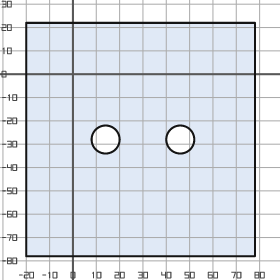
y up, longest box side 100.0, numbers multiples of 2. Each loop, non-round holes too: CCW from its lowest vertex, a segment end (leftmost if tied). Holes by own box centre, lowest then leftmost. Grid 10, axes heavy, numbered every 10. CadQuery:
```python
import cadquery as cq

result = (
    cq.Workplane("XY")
    .moveTo(-20.0, -78.0)
    .lineTo(78.0, -78.0)
    .lineTo(78.0, 22.0)
    .lineTo(-20.0, 22.0)
    .close()
    .moveTo(14.0, -28.0)
    .circle(6.0)
    .moveTo(46.0, -28.0)
    .circle(6.0)
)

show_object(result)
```